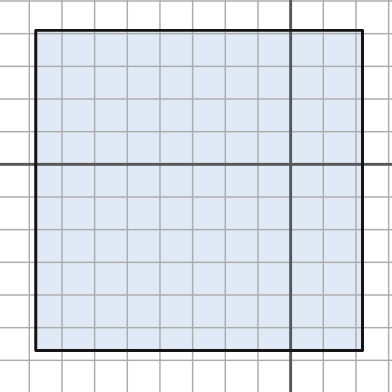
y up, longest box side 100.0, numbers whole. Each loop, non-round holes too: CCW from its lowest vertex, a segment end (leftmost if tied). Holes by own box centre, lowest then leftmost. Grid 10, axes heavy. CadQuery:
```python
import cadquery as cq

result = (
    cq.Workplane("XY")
    .moveTo(-78.0, -57.0)
    .lineTo(22.0, -57.0)
    .lineTo(22.0, 41.0)
    .lineTo(-78.0, 41.0)
    .close()
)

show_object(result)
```